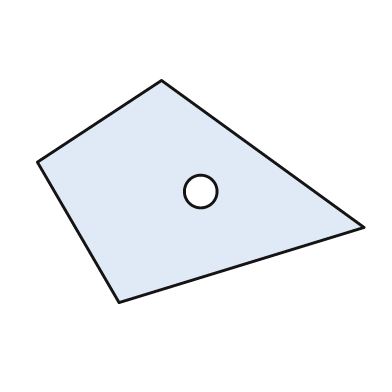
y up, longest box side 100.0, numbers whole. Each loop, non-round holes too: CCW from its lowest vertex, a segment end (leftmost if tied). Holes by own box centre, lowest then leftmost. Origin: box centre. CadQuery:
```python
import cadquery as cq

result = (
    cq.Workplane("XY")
    .moveTo(-25.0, -34.0)
    .lineTo(50.0, -11.0)
    .lineTo(-12.0, 34.0)
    .lineTo(-50.0, 9.0)
    .close()
    .moveTo(0.0, 0.0)
    .circle(5.0)
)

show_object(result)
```